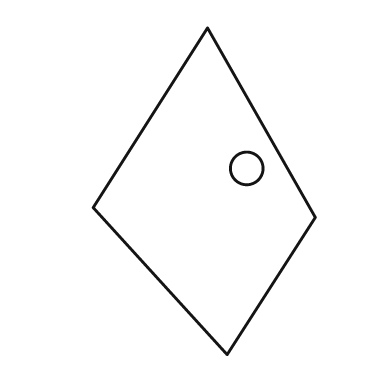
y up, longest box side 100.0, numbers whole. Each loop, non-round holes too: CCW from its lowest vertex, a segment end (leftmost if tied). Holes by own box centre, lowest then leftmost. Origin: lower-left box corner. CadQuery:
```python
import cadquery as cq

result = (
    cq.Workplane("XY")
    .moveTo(41.0, 0.0)
    .lineTo(68.0, 42.0)
    .lineTo(35.0, 100.0)
    .lineTo(0.0, 45.0)
    .close()
    .moveTo(47.0, 57.0)
    .circle(5.0)
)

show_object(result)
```